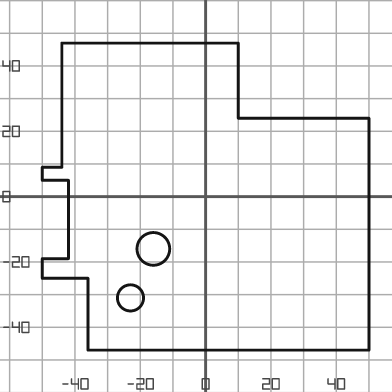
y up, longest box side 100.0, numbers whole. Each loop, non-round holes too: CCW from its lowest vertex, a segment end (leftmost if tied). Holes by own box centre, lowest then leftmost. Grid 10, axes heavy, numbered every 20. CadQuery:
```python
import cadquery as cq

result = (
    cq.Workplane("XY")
    .moveTo(-36.0, -47.0)
    .lineTo(50.0, -47.0)
    .lineTo(50.0, 24.0)
    .lineTo(10.0, 24.0)
    .lineTo(10.0, 47.0)
    .lineTo(-44.0, 47.0)
    .lineTo(-44.0, 9.0)
    .lineTo(-50.0, 9.0)
    .lineTo(-50.0, 5.0)
    .lineTo(-42.0, 5.0)
    .lineTo(-42.0, -19.0)
    .lineTo(-50.0, -19.0)
    .lineTo(-50.0, -25.0)
    .lineTo(-36.0, -25.0)
    .close()
    .moveTo(-23.0, -31.0)
    .circle(4.0)
    .moveTo(-16.0, -16.0)
    .circle(5.0)
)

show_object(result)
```